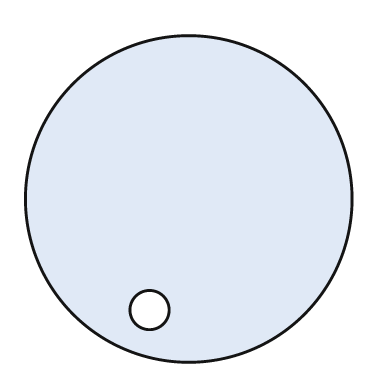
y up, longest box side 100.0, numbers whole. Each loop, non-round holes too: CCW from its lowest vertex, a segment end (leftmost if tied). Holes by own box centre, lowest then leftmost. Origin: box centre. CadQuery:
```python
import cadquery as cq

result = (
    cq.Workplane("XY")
    .moveTo(0.0, 0.0)
    .circle(50.0)
    .moveTo(-12.0, -34.0)
    .circle(6.0)
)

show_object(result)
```